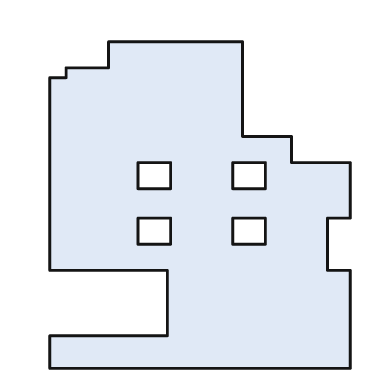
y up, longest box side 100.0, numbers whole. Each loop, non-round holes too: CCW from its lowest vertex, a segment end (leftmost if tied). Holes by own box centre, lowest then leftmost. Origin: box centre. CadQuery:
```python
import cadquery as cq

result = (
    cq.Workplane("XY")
    .moveTo(-46.0, -50.0)
    .lineTo(46.0, -50.0)
    .lineTo(46.0, -20.0)
    .lineTo(39.0, -20.0)
    .lineTo(39.0, -4.0)
    .lineTo(46.0, -4.0)
    .lineTo(46.0, 13.0)
    .lineTo(28.0, 13.0)
    .lineTo(28.0, 21.0)
    .lineTo(13.0, 21.0)
    .lineTo(13.0, 50.0)
    .lineTo(-28.0, 50.0)
    .lineTo(-28.0, 42.0)
    .lineTo(-41.0, 42.0)
    .lineTo(-41.0, 39.0)
    .lineTo(-46.0, 39.0)
    .lineTo(-46.0, -20.0)
    .lineTo(-10.0, -20.0)
    .lineTo(-10.0, -40.0)
    .lineTo(-46.0, -40.0)
    .close()
    .moveTo(-19.0, -12.0)
    .lineTo(-9.0, -12.0)
    .lineTo(-9.0, -4.0)
    .lineTo(-19.0, -4.0)
    .close()
    .moveTo(10.0, -12.0)
    .lineTo(20.0, -12.0)
    .lineTo(20.0, -4.0)
    .lineTo(10.0, -4.0)
    .close()
    .moveTo(-19.0, 5.0)
    .lineTo(-9.0, 5.0)
    .lineTo(-9.0, 13.0)
    .lineTo(-19.0, 13.0)
    .close()
    .moveTo(10.0, 5.0)
    .lineTo(20.0, 5.0)
    .lineTo(20.0, 13.0)
    .lineTo(10.0, 13.0)
    .close()
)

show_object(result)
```